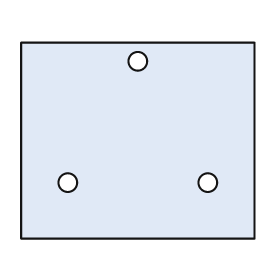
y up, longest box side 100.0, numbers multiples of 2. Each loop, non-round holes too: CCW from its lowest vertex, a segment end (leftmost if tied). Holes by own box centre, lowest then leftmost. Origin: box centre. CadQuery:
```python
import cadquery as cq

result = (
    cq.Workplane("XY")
    .moveTo(-50.0, -42.0)
    .lineTo(50.0, -42.0)
    .lineTo(50.0, 42.0)
    .lineTo(-50.0, 42.0)
    .close()
    .moveTo(-30.0, -18.0)
    .circle(4.0)
    .moveTo(30.0, -18.0)
    .circle(4.0)
    .moveTo(0.0, 34.0)
    .circle(4.0)
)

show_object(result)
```